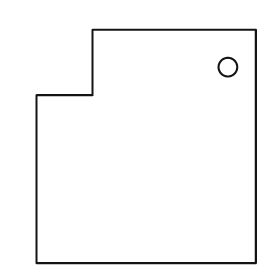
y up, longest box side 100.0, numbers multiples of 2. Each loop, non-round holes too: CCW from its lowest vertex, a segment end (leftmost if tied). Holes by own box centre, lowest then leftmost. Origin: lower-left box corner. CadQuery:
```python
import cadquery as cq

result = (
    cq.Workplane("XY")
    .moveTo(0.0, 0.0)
    .lineTo(94.0, 0.0)
    .lineTo(94.0, 100.0)
    .lineTo(24.0, 100.0)
    .lineTo(24.0, 72.0)
    .lineTo(0.0, 72.0)
    .close()
    .moveTo(82.0, 84.0)
    .circle(4.0)
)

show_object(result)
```